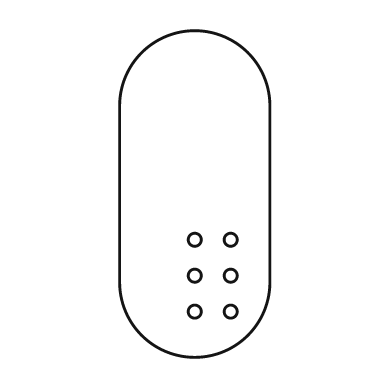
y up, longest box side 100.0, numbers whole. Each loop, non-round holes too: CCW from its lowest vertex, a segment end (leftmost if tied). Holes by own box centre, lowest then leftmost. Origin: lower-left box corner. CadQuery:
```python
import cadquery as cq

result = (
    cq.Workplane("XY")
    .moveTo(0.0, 23.0)
    .threePointArc((23.0, 0.0), (46.0, 23.0))
    .lineTo(46.0, 77.0)
    .threePointArc((23.0, 100.0), (0.0, 77.0))
    .close()
    .moveTo(23.0, 14.0)
    .circle(2.0)
    .moveTo(34.0, 14.0)
    .circle(2.0)
    .moveTo(23.0, 25.0)
    .circle(2.0)
    .moveTo(34.0, 25.0)
    .circle(2.0)
    .moveTo(23.0, 36.0)
    .circle(2.0)
    .moveTo(34.0, 36.0)
    .circle(2.0)
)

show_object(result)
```